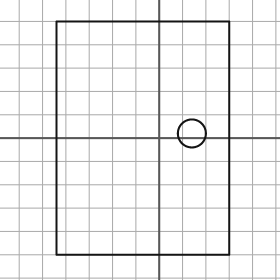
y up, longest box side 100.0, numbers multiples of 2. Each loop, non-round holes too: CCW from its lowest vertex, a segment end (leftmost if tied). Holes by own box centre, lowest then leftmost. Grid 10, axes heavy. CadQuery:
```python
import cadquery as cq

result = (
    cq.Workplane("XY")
    .moveTo(-44.0, -50.0)
    .lineTo(30.0, -50.0)
    .lineTo(30.0, 50.0)
    .lineTo(-44.0, 50.0)
    .close()
    .moveTo(14.0, 2.0)
    .circle(6.0)
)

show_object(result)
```